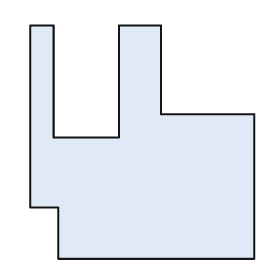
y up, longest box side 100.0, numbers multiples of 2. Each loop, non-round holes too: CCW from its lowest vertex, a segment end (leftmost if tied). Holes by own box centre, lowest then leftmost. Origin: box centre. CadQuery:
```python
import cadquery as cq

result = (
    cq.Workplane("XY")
    .moveTo(-36.0, -50.0)
    .lineTo(48.0, -50.0)
    .lineTo(48.0, 12.0)
    .lineTo(8.0, 12.0)
    .lineTo(8.0, 50.0)
    .lineTo(-10.0, 50.0)
    .lineTo(-10.0, 2.0)
    .lineTo(-38.0, 2.0)
    .lineTo(-38.0, 50.0)
    .lineTo(-48.0, 50.0)
    .lineTo(-48.0, -28.0)
    .lineTo(-36.0, -28.0)
    .close()
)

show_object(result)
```